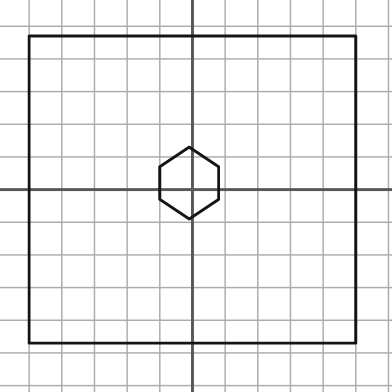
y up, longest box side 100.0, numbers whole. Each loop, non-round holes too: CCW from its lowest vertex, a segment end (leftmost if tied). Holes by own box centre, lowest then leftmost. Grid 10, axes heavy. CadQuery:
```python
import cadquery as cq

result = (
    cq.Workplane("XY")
    .moveTo(-50.0, -47.0)
    .lineTo(50.0, -47.0)
    .lineTo(50.0, 47.0)
    .lineTo(-50.0, 47.0)
    .close()
    .moveTo(-1.0, -9.0)
    .lineTo(8.0, -3.0)
    .lineTo(8.0, 7.0)
    .lineTo(-1.0, 13.0)
    .lineTo(-10.0, 7.0)
    .lineTo(-10.0, -3.0)
    .close()
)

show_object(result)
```